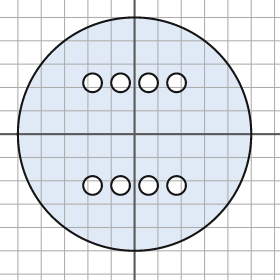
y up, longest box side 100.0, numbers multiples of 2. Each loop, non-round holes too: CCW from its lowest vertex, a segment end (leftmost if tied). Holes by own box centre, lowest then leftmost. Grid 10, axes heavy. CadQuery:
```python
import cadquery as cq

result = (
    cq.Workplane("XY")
    .moveTo(0.0, 0.0)
    .circle(50.0)
    .moveTo(-18.0, -22.0)
    .circle(4.0)
    .moveTo(-6.0, -22.0)
    .circle(4.0)
    .moveTo(6.0, -22.0)
    .circle(4.0)
    .moveTo(18.0, -22.0)
    .circle(4.0)
    .moveTo(-18.0, 22.0)
    .circle(4.0)
    .moveTo(-6.0, 22.0)
    .circle(4.0)
    .moveTo(6.0, 22.0)
    .circle(4.0)
    .moveTo(18.0, 22.0)
    .circle(4.0)
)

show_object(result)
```